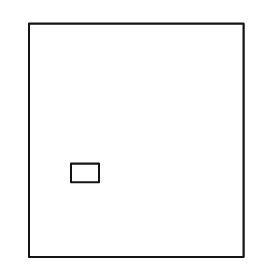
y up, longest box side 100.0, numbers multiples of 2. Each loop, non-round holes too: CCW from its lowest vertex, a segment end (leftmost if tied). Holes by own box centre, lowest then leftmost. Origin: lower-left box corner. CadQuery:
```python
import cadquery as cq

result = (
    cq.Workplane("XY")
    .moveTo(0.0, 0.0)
    .lineTo(92.0, 0.0)
    .lineTo(92.0, 100.0)
    .lineTo(0.0, 100.0)
    .close()
    .moveTo(18.0, 32.0)
    .lineTo(30.0, 32.0)
    .lineTo(30.0, 40.0)
    .lineTo(18.0, 40.0)
    .close()
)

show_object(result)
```